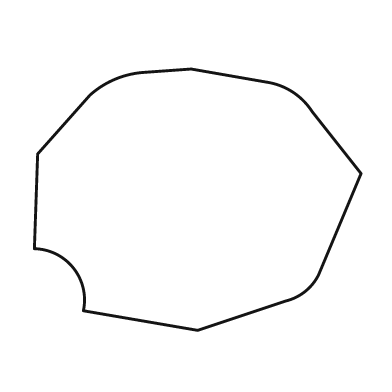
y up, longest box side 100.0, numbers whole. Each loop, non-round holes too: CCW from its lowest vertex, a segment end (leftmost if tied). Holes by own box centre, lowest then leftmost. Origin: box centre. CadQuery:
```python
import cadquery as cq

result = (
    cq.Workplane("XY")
    .moveTo(0.0, -40.0)
    .lineTo(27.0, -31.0)
    .threePointArc((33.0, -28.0), (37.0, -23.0))
    .lineTo(50.0, 8.0)
    .lineTo(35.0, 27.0)
    .threePointArc((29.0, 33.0), (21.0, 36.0))
    .lineTo(-2.0, 40.0)
    .lineTo(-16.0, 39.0)
    .threePointArc((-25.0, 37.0), (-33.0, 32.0))
    .lineTo(-49.0, 14.0)
    .lineTo(-50.0, -15.0)
    .threePointArc((-38.0, -21.0), (-35.0, -34.0))
    .close()
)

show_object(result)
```